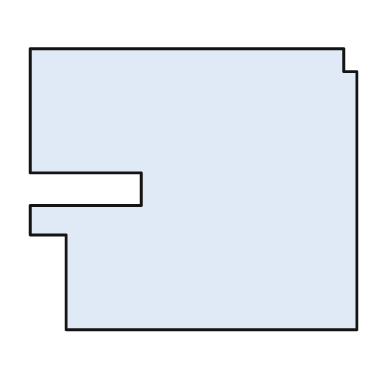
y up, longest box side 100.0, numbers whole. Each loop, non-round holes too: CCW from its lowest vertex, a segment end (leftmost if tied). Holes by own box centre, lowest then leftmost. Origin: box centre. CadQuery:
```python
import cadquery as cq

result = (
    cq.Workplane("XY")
    .moveTo(-39.0, -43.0)
    .lineTo(50.0, -43.0)
    .lineTo(50.0, 36.0)
    .lineTo(46.0, 36.0)
    .lineTo(46.0, 43.0)
    .lineTo(-50.0, 43.0)
    .lineTo(-50.0, 5.0)
    .lineTo(-16.0, 5.0)
    .lineTo(-16.0, -5.0)
    .lineTo(-50.0, -5.0)
    .lineTo(-50.0, -14.0)
    .lineTo(-39.0, -14.0)
    .close()
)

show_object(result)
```